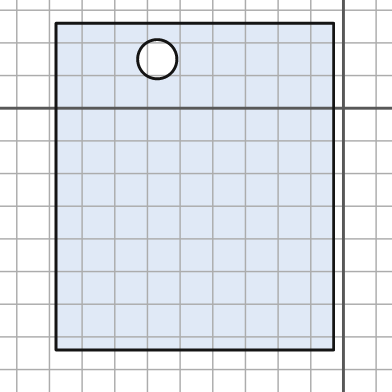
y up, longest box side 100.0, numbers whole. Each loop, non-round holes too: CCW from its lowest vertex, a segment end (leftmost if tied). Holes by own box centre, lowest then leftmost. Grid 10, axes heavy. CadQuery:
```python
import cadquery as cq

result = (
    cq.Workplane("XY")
    .moveTo(-88.0, -74.0)
    .lineTo(-3.0, -74.0)
    .lineTo(-3.0, 26.0)
    .lineTo(-88.0, 26.0)
    .close()
    .moveTo(-57.0, 15.0)
    .circle(6.0)
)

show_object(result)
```